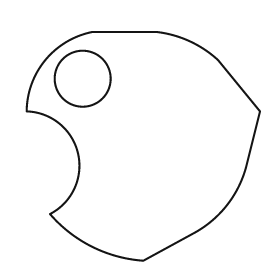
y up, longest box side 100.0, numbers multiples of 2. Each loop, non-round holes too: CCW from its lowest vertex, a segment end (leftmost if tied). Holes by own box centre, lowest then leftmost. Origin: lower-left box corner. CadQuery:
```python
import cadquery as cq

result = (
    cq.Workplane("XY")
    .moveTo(50.0, 0.0)
    .lineTo(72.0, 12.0)
    .threePointArc((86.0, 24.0), (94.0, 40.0))
    .lineTo(100.0, 64.0)
    .lineTo(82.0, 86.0)
    .threePointArc((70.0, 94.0), (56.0, 98.0))
    .lineTo(28.0, 98.0)
    .threePointArc((8.0, 86.0), (0.0, 64.0))
    .threePointArc((22.0, 46.0), (10.0, 20.0))
    .threePointArc((28.0, 6.0), (50.0, 0.0))
    .close()
    .moveTo(24.0, 78.0)
    .circle(12.0)
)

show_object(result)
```